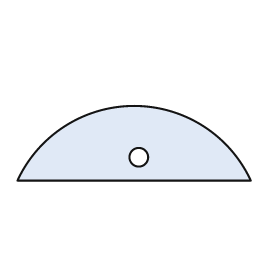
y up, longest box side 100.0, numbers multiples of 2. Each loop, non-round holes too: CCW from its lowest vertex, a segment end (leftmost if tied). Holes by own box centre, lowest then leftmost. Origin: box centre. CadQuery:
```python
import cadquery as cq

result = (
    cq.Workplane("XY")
    .moveTo(-50.0, -16.0)
    .lineTo(50.0, -16.0)
    .threePointArc((0.0, 16.0), (-50.0, -16.0))
    .close()
    .moveTo(2.0, -6.0)
    .circle(4.0)
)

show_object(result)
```